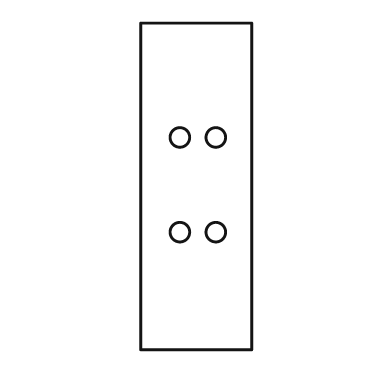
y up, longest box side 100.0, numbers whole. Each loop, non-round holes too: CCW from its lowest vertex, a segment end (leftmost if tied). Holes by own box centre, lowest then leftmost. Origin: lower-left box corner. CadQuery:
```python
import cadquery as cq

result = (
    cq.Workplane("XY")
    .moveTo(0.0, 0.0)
    .lineTo(34.0, 0.0)
    .lineTo(34.0, 100.0)
    .lineTo(0.0, 100.0)
    .close()
    .moveTo(12.0, 36.0)
    .circle(3.0)
    .moveTo(23.0, 36.0)
    .circle(3.0)
    .moveTo(12.0, 65.0)
    .circle(3.0)
    .moveTo(23.0, 65.0)
    .circle(3.0)
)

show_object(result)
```